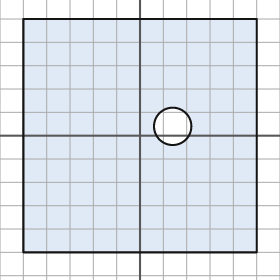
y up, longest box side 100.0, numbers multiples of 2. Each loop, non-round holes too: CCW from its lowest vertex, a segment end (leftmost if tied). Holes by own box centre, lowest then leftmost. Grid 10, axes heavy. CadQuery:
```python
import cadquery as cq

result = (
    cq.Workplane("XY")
    .moveTo(-50.0, -50.0)
    .lineTo(50.0, -50.0)
    .lineTo(50.0, 50.0)
    .lineTo(-50.0, 50.0)
    .close()
    .moveTo(14.0, 4.0)
    .circle(8.0)
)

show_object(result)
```